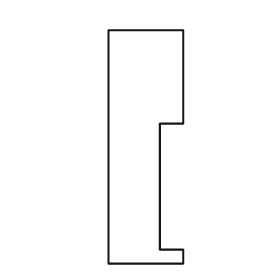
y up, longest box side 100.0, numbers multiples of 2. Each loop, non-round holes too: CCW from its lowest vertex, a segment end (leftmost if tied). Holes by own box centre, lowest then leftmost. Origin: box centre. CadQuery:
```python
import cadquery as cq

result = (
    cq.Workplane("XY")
    .moveTo(-16.0, -50.0)
    .lineTo(16.0, -50.0)
    .lineTo(16.0, -44.0)
    .lineTo(6.0, -44.0)
    .lineTo(6.0, 10.0)
    .lineTo(16.0, 10.0)
    .lineTo(16.0, 50.0)
    .lineTo(-16.0, 50.0)
    .close()
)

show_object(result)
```